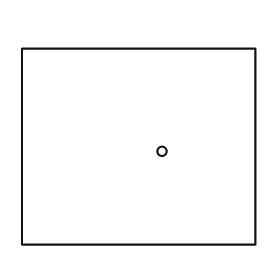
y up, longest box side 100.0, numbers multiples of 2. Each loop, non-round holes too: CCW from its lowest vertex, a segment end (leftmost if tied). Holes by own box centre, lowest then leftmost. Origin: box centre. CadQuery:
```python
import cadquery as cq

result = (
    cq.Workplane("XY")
    .moveTo(-50.0, -42.0)
    .lineTo(50.0, -42.0)
    .lineTo(50.0, 42.0)
    .lineTo(-50.0, 42.0)
    .close()
    .moveTo(10.0, -2.0)
    .circle(2.0)
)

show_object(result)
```